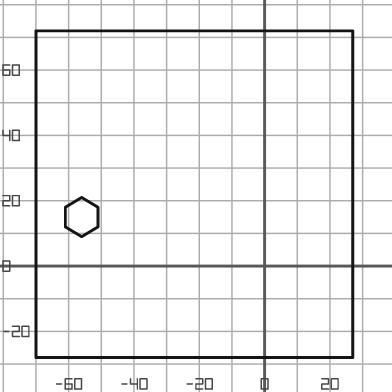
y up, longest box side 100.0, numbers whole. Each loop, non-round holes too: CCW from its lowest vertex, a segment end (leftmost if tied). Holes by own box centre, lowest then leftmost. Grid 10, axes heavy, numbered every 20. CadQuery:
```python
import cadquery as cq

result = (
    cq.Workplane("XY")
    .moveTo(-70.0, -28.0)
    .lineTo(27.0, -28.0)
    .lineTo(27.0, 72.0)
    .lineTo(-70.0, 72.0)
    .close()
    .moveTo(-56.0, 9.0)
    .lineTo(-51.0, 12.0)
    .lineTo(-51.0, 18.0)
    .lineTo(-56.0, 21.0)
    .lineTo(-61.0, 18.0)
    .lineTo(-61.0, 12.0)
    .close()
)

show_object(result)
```